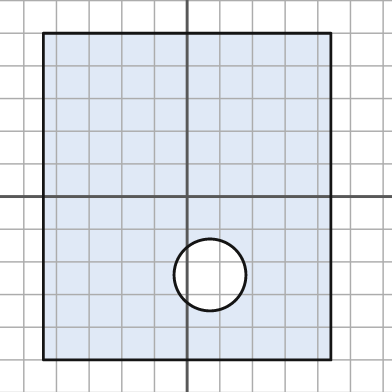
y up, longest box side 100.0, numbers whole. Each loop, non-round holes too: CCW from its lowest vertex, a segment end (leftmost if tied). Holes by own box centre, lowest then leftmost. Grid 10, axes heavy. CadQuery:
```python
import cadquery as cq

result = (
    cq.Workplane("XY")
    .moveTo(-44.0, -50.0)
    .lineTo(44.0, -50.0)
    .lineTo(44.0, 50.0)
    .lineTo(-44.0, 50.0)
    .close()
    .moveTo(7.0, -24.0)
    .circle(11.0)
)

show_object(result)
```